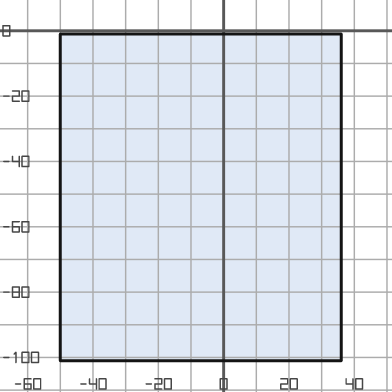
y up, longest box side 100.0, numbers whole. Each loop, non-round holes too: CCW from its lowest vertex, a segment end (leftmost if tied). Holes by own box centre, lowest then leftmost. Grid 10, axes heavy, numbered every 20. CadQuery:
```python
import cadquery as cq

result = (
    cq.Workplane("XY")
    .moveTo(-50.0, -101.0)
    .lineTo(36.0, -101.0)
    .lineTo(36.0, -1.0)
    .lineTo(-50.0, -1.0)
    .close()
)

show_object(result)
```